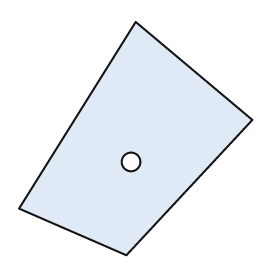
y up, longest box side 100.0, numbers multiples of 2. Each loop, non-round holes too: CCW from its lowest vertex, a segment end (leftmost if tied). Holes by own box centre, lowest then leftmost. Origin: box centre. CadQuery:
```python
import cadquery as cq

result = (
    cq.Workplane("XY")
    .moveTo(-4.0, -50.0)
    .lineTo(50.0, 8.0)
    .lineTo(0.0, 50.0)
    .lineTo(-50.0, -30.0)
    .close()
    .moveTo(-2.0, -10.0)
    .circle(4.0)
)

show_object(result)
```